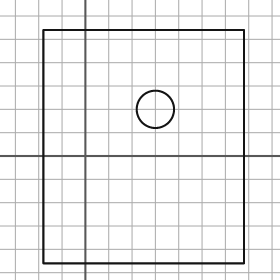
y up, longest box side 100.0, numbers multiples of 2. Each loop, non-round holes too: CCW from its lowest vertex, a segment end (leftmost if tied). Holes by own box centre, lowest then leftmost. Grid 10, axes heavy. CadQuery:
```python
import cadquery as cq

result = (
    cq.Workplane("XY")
    .moveTo(-18.0, -46.0)
    .lineTo(68.0, -46.0)
    .lineTo(68.0, 54.0)
    .lineTo(-18.0, 54.0)
    .close()
    .moveTo(30.0, 20.0)
    .circle(8.0)
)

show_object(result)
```